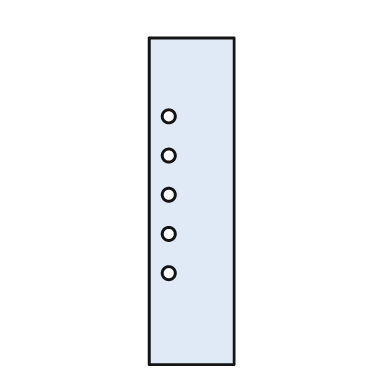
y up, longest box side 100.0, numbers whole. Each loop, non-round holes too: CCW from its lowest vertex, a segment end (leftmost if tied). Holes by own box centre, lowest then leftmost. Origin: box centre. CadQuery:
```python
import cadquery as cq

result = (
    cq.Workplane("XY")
    .moveTo(-13.0, -50.0)
    .lineTo(13.0, -50.0)
    .lineTo(13.0, 50.0)
    .lineTo(-13.0, 50.0)
    .close()
    .moveTo(-7.0, -22.0)
    .circle(2.0)
    .moveTo(-7.0, -10.0)
    .circle(2.0)
    .moveTo(-7.0, 2.0)
    .circle(2.0)
    .moveTo(-7.0, 14.0)
    .circle(2.0)
    .moveTo(-7.0, 26.0)
    .circle(2.0)
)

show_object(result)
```